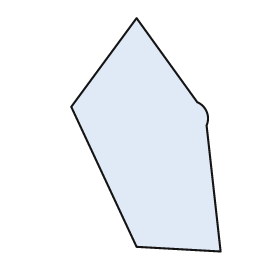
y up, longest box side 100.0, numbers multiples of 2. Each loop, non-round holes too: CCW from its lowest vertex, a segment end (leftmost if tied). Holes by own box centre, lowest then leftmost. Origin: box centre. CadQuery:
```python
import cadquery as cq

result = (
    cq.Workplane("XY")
    .moveTo(32.0, -50.0)
    .lineTo(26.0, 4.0)
    .threePointArc((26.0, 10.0), (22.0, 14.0))
    .lineTo(-4.0, 50.0)
    .lineTo(-32.0, 12.0)
    .lineTo(-4.0, -48.0)
    .close()
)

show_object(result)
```